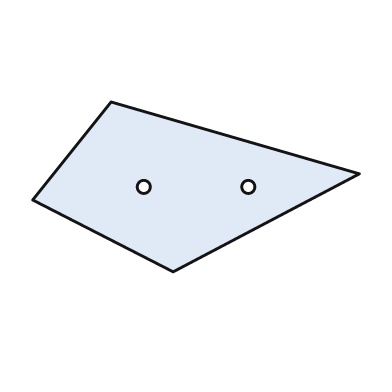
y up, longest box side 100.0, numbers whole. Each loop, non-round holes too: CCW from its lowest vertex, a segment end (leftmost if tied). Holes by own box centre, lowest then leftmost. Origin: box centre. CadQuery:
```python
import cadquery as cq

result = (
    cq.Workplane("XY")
    .moveTo(-7.0, -26.0)
    .lineTo(50.0, 4.0)
    .lineTo(-26.0, 26.0)
    .lineTo(-50.0, -4.0)
    .close()
    .moveTo(-16.0, 0.0)
    .circle(2.0)
    .moveTo(16.0, 0.0)
    .circle(2.0)
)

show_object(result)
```